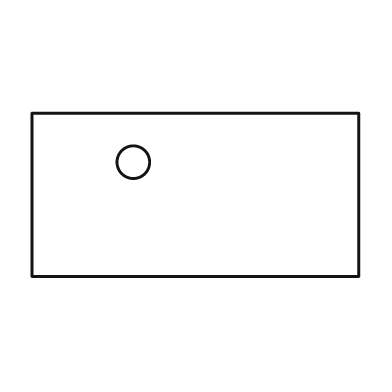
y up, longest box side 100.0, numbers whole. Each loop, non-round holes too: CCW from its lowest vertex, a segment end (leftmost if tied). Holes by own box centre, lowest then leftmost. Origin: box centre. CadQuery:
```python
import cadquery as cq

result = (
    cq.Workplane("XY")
    .moveTo(-50.0, -25.0)
    .lineTo(50.0, -25.0)
    .lineTo(50.0, 25.0)
    .lineTo(-50.0, 25.0)
    .close()
    .moveTo(-19.0, 10.0)
    .circle(5.0)
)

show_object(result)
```